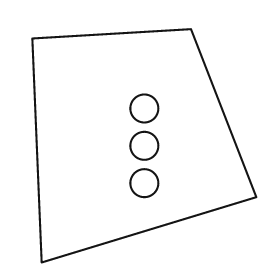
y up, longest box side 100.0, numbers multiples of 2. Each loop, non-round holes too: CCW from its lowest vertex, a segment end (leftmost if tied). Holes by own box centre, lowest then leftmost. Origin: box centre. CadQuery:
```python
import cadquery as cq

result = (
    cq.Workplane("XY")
    .moveTo(-44.0, -50.0)
    .lineTo(48.0, -22.0)
    .lineTo(20.0, 50.0)
    .lineTo(-48.0, 46.0)
    .close()
    .moveTo(0.0, -16.0)
    .circle(6.0)
    .moveTo(0.0, 0.0)
    .circle(6.0)
    .moveTo(0.0, 16.0)
    .circle(6.0)
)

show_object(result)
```